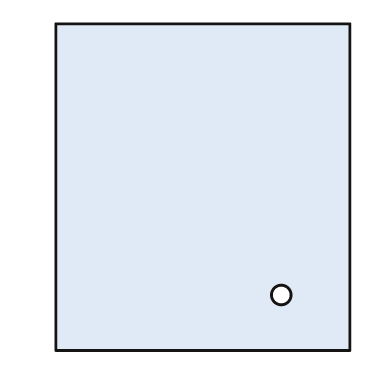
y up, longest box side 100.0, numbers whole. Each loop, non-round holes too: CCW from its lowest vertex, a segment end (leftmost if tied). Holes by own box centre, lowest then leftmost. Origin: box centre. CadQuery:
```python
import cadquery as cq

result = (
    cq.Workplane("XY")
    .moveTo(-45.0, -50.0)
    .lineTo(45.0, -50.0)
    .lineTo(45.0, 50.0)
    .lineTo(-45.0, 50.0)
    .close()
    .moveTo(24.0, -33.0)
    .circle(3.0)
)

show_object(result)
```